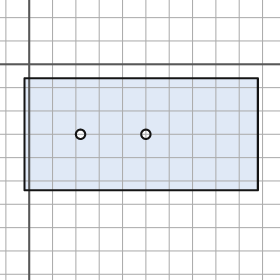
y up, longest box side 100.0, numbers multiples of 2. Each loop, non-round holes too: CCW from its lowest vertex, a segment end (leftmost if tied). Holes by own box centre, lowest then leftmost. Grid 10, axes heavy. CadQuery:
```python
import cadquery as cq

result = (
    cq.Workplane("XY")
    .moveTo(-2.0, -54.0)
    .lineTo(98.0, -54.0)
    .lineTo(98.0, -6.0)
    .lineTo(-2.0, -6.0)
    .close()
    .moveTo(22.0, -30.0)
    .circle(2.0)
    .moveTo(50.0, -30.0)
    .circle(2.0)
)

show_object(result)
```